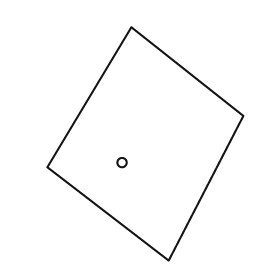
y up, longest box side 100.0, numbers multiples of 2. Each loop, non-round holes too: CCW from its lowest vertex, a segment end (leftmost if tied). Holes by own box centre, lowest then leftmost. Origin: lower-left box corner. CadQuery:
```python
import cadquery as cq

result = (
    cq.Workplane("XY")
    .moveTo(52.0, 0.0)
    .lineTo(84.0, 62.0)
    .lineTo(36.0, 100.0)
    .lineTo(0.0, 40.0)
    .close()
    .moveTo(32.0, 42.0)
    .circle(2.0)
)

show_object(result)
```